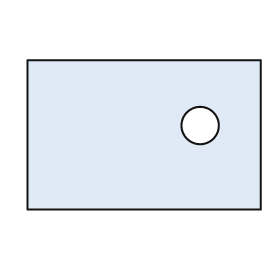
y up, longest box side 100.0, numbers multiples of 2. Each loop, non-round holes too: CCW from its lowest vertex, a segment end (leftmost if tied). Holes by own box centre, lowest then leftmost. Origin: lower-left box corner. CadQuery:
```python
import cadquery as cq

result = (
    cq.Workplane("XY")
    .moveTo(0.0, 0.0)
    .lineTo(100.0, 0.0)
    .lineTo(100.0, 64.0)
    .lineTo(0.0, 64.0)
    .close()
    .moveTo(74.0, 36.0)
    .circle(8.0)
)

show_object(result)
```